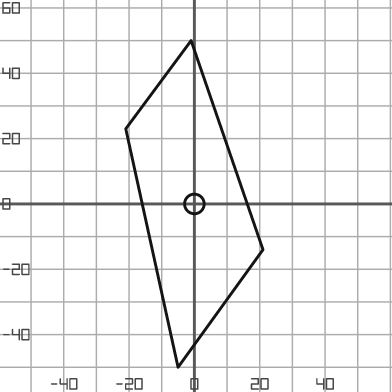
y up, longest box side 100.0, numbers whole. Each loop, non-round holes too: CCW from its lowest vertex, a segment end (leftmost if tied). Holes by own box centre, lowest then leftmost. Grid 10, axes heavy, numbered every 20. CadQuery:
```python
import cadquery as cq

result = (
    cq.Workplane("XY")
    .moveTo(-5.0, -50.0)
    .lineTo(21.0, -14.0)
    .lineTo(-1.0, 50.0)
    .lineTo(-21.0, 23.0)
    .close()
    .moveTo(0.0, 0.0)
    .circle(3.0)
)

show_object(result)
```